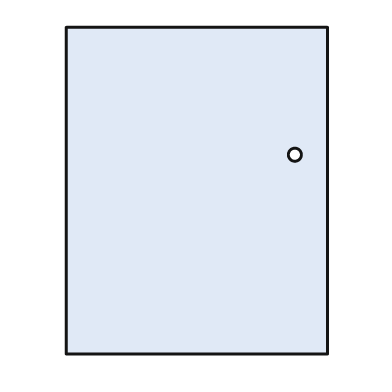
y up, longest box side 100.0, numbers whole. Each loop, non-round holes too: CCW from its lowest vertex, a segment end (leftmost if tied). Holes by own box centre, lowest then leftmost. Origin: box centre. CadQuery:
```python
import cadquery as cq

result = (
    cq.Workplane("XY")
    .moveTo(-40.0, -50.0)
    .lineTo(40.0, -50.0)
    .lineTo(40.0, 50.0)
    .lineTo(-40.0, 50.0)
    .close()
    .moveTo(30.0, 11.0)
    .circle(2.0)
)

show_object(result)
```